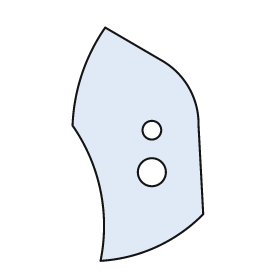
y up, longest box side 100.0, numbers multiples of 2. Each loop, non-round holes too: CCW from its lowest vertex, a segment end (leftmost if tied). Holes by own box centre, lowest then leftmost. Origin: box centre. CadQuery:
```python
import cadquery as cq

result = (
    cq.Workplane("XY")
    .moveTo(-16.0, -50.0)
    .threePointArc((8.0, -44.0), (28.0, -30.0))
    .lineTo(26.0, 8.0)
    .threePointArc((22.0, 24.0), (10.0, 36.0))
    .lineTo(-14.0, 50.0)
    .threePointArc((-24.0, 30.0), (-28.0, 8.0))
    .threePointArc((-16.0, -20.0), (-16.0, -50.0))
    .close()
    .moveTo(6.0, -12.0)
    .circle(6.0)
    .moveTo(6.0, 6.0)
    .circle(4.0)
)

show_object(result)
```